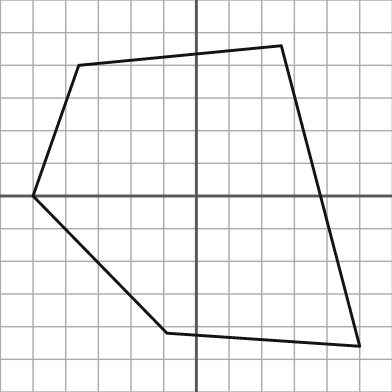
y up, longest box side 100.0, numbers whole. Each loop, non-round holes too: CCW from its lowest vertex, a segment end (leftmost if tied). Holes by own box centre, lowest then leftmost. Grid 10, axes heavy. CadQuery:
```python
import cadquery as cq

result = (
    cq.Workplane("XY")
    .moveTo(50.0, -46.0)
    .lineTo(26.0, 46.0)
    .lineTo(-36.0, 40.0)
    .lineTo(-50.0, 0.0)
    .lineTo(-9.0, -42.0)
    .close()
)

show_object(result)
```